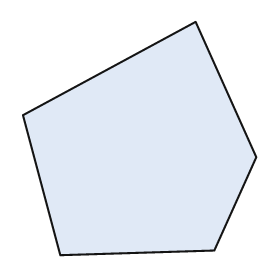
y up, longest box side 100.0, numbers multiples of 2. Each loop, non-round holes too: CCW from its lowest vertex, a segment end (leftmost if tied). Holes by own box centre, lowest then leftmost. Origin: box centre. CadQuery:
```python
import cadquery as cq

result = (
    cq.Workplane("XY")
    .moveTo(-34.0, -50.0)
    .lineTo(32.0, -48.0)
    .lineTo(50.0, -8.0)
    .lineTo(24.0, 50.0)
    .lineTo(-50.0, 10.0)
    .close()
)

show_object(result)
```